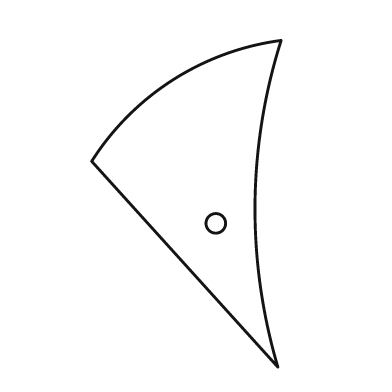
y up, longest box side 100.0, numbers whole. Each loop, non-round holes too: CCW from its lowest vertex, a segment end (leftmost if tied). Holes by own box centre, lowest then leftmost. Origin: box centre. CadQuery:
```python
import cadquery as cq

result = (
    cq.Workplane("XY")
    .moveTo(28.0, -50.0)
    .threePointArc((21.0, 0.0), (29.0, 50.0))
    .threePointArc((-4.0, 38.0), (-29.0, 13.0))
    .close()
    .moveTo(9.0, -6.0)
    .circle(3.0)
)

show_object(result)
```